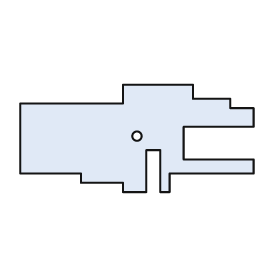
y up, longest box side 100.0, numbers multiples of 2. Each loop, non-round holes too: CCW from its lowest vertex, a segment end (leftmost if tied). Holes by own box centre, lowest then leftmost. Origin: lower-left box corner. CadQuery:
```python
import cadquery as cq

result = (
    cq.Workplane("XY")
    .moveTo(44.0, 0.0)
    .lineTo(54.0, 0.0)
    .lineTo(54.0, 18.0)
    .lineTo(60.0, 18.0)
    .lineTo(60.0, 0.0)
    .lineTo(64.0, 0.0)
    .lineTo(64.0, 8.0)
    .lineTo(100.0, 8.0)
    .lineTo(100.0, 14.0)
    .lineTo(70.0, 14.0)
    .lineTo(70.0, 28.0)
    .lineTo(100.0, 28.0)
    .lineTo(100.0, 36.0)
    .lineTo(90.0, 36.0)
    .lineTo(90.0, 40.0)
    .lineTo(74.0, 40.0)
    .lineTo(74.0, 46.0)
    .lineTo(44.0, 46.0)
    .lineTo(44.0, 38.0)
    .lineTo(0.0, 38.0)
    .lineTo(0.0, 8.0)
    .lineTo(26.0, 8.0)
    .lineTo(26.0, 4.0)
    .lineTo(44.0, 4.0)
    .close()
    .moveTo(50.0, 24.0)
    .circle(2.0)
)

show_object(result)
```